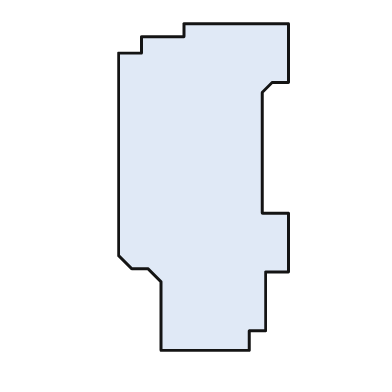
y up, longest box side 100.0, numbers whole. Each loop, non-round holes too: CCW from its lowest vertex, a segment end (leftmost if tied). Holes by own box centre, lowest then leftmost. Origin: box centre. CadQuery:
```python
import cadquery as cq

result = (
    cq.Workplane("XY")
    .moveTo(-13.0, -50.0)
    .lineTo(14.0, -50.0)
    .lineTo(14.0, -44.0)
    .lineTo(19.0, -44.0)
    .lineTo(19.0, -26.0)
    .lineTo(26.0, -26.0)
    .lineTo(26.0, -8.0)
    .lineTo(18.0, -8.0)
    .lineTo(18.0, 29.0)
    .lineTo(21.0, 32.0)
    .lineTo(26.0, 32.0)
    .lineTo(26.0, 50.0)
    .lineTo(-6.0, 50.0)
    .lineTo(-6.0, 46.0)
    .lineTo(-19.0, 46.0)
    .lineTo(-19.0, 41.0)
    .lineTo(-26.0, 41.0)
    .lineTo(-26.0, -21.0)
    .lineTo(-22.0, -25.0)
    .lineTo(-17.0, -25.0)
    .lineTo(-13.0, -29.0)
    .close()
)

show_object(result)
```